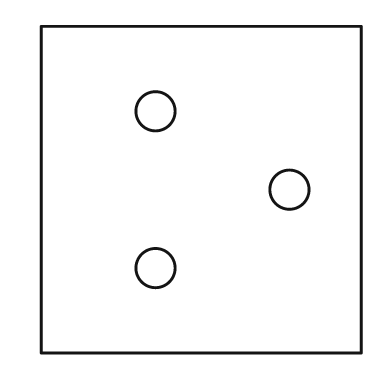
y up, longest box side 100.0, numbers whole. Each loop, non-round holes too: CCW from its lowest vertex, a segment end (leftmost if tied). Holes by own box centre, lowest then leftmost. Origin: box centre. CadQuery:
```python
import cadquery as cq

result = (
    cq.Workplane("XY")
    .moveTo(-49.0, -50.0)
    .lineTo(49.0, -50.0)
    .lineTo(49.0, 50.0)
    .lineTo(-49.0, 50.0)
    .close()
    .moveTo(-14.0, -24.0)
    .circle(6.0)
    .moveTo(27.0, 0.0)
    .circle(6.0)
    .moveTo(-14.0, 24.0)
    .circle(6.0)
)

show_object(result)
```